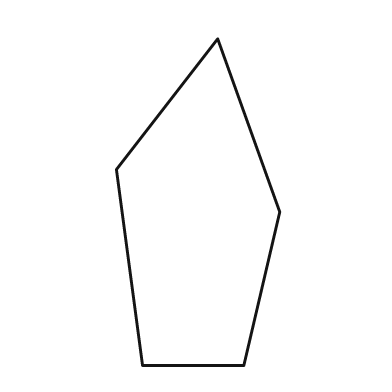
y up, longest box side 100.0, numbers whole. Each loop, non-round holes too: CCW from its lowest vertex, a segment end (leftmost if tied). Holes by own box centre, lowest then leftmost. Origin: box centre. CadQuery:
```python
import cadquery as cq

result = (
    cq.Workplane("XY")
    .moveTo(-17.0, -50.0)
    .lineTo(14.0, -50.0)
    .lineTo(25.0, -3.0)
    .lineTo(6.0, 50.0)
    .lineTo(-25.0, 10.0)
    .close()
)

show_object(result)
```